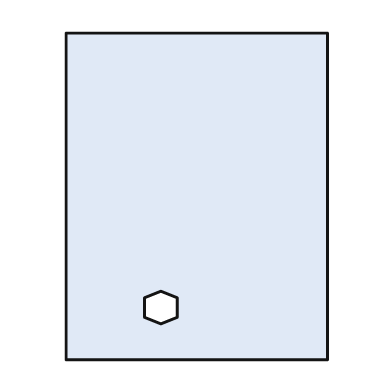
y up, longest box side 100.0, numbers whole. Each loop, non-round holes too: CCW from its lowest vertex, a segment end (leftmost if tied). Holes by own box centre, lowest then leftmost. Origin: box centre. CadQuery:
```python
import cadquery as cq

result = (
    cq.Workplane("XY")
    .moveTo(-40.0, -50.0)
    .lineTo(40.0, -50.0)
    .lineTo(40.0, 50.0)
    .lineTo(-40.0, 50.0)
    .close()
    .moveTo(-11.0, -39.0)
    .lineTo(-6.0, -37.0)
    .lineTo(-6.0, -31.0)
    .lineTo(-11.0, -29.0)
    .lineTo(-16.0, -31.0)
    .lineTo(-16.0, -37.0)
    .close()
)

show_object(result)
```